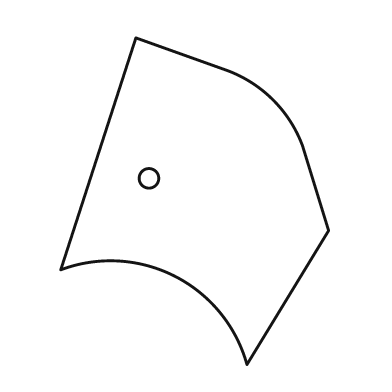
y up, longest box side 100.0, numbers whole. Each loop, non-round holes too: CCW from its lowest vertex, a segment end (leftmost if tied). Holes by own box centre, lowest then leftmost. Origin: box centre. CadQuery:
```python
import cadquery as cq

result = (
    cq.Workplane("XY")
    .moveTo(16.0, -50.0)
    .lineTo(41.0, -9.0)
    .lineTo(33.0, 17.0)
    .threePointArc((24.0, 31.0), (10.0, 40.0))
    .lineTo(-18.0, 50.0)
    .lineTo(-41.0, -21.0)
    .threePointArc((-6.0, -23.0), (16.0, -50.0))
    .close()
    .moveTo(-14.0, 7.0)
    .circle(3.0)
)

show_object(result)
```